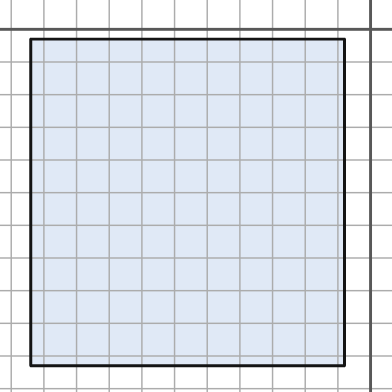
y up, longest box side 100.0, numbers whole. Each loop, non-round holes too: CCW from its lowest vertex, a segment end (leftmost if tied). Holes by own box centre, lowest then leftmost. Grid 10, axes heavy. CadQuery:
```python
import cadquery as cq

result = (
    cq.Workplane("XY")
    .moveTo(-104.0, -103.0)
    .lineTo(-8.0, -103.0)
    .lineTo(-8.0, -3.0)
    .lineTo(-104.0, -3.0)
    .close()
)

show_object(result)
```